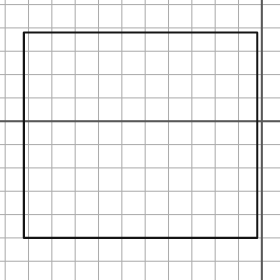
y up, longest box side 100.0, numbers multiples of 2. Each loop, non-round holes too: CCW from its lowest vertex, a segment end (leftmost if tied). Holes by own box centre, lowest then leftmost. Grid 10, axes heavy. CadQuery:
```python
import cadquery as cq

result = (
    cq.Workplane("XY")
    .moveTo(-102.0, -50.0)
    .lineTo(-2.0, -50.0)
    .lineTo(-2.0, 38.0)
    .lineTo(-102.0, 38.0)
    .close()
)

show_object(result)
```